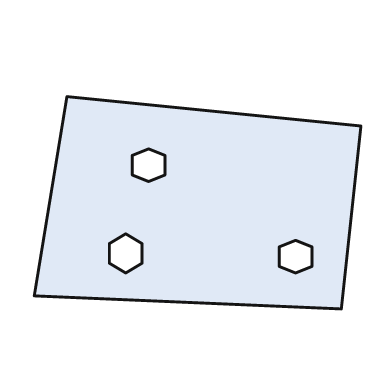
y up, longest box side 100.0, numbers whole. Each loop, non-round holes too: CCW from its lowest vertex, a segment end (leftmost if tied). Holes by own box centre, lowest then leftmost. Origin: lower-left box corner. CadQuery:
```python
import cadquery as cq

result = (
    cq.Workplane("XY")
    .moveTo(94.0, 0.0)
    .lineTo(100.0, 56.0)
    .lineTo(10.0, 65.0)
    .lineTo(0.0, 4.0)
    .close()
    .moveTo(80.0, 11.0)
    .lineTo(85.0, 13.0)
    .lineTo(85.0, 19.0)
    .lineTo(80.0, 21.0)
    .lineTo(75.0, 19.0)
    .lineTo(75.0, 13.0)
    .close()
    .moveTo(28.0, 11.0)
    .lineTo(33.0, 14.0)
    .lineTo(33.0, 20.0)
    .lineTo(28.0, 23.0)
    .lineTo(23.0, 20.0)
    .lineTo(23.0, 14.0)
    .close()
    .moveTo(35.0, 39.0)
    .lineTo(40.0, 41.0)
    .lineTo(40.0, 47.0)
    .lineTo(35.0, 49.0)
    .lineTo(30.0, 47.0)
    .lineTo(30.0, 41.0)
    .close()
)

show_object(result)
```